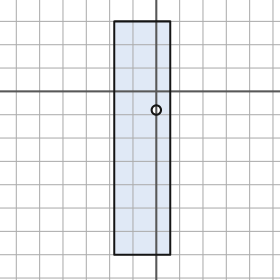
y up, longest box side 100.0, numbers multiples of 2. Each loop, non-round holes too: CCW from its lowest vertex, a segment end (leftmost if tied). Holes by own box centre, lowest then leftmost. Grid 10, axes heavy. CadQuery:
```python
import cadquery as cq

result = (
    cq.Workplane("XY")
    .moveTo(-18.0, -70.0)
    .lineTo(6.0, -70.0)
    .lineTo(6.0, 30.0)
    .lineTo(-18.0, 30.0)
    .close()
    .moveTo(0.0, -8.0)
    .circle(2.0)
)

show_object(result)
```